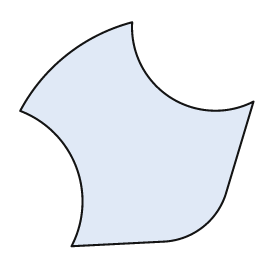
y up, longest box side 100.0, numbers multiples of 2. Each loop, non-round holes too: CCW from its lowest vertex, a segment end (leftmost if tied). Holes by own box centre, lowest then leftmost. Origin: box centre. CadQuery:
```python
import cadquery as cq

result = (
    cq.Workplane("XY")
    .moveTo(-28.0, -48.0)
    .lineTo(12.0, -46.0)
    .threePointArc((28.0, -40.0), (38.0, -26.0))
    .lineTo(50.0, 14.0)
    .threePointArc((14.0, 16.0), (-2.0, 48.0))
    .threePointArc((-30.0, 34.0), (-50.0, 10.0))
    .threePointArc((-26.0, -14.0), (-28.0, -48.0))
    .close()
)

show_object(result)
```